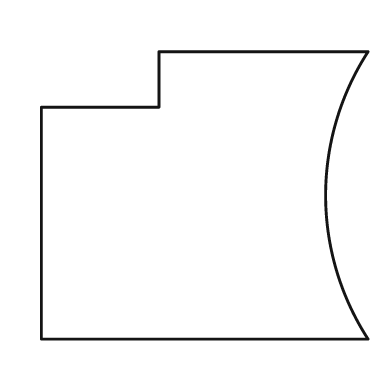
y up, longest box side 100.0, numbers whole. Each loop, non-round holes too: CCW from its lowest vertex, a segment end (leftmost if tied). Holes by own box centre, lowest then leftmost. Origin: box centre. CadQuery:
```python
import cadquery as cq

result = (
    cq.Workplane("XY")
    .moveTo(-50.0, -44.0)
    .lineTo(50.0, -44.0)
    .threePointArc((37.0, 0.0), (50.0, 44.0))
    .lineTo(-14.0, 44.0)
    .lineTo(-14.0, 27.0)
    .lineTo(-50.0, 27.0)
    .close()
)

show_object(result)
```